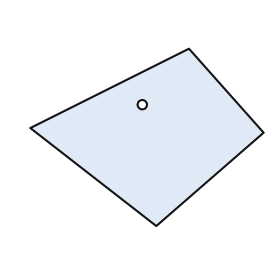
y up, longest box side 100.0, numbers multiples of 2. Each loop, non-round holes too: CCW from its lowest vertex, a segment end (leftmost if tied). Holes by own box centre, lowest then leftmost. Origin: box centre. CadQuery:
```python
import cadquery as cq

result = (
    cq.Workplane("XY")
    .moveTo(4.0, -38.0)
    .lineTo(50.0, 2.0)
    .lineTo(18.0, 38.0)
    .lineTo(-50.0, 4.0)
    .close()
    .moveTo(-2.0, 14.0)
    .circle(2.0)
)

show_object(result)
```